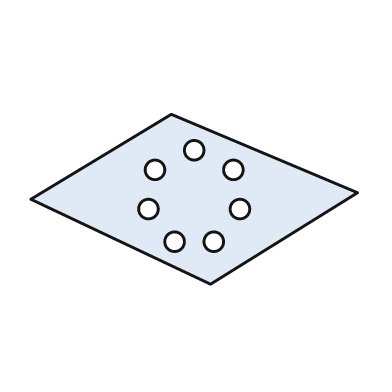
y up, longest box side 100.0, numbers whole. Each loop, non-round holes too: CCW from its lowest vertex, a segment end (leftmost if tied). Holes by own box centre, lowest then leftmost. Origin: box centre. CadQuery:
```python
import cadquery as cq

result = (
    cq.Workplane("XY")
    .moveTo(5.0, -26.0)
    .lineTo(50.0, 2.0)
    .lineTo(-7.0, 26.0)
    .lineTo(-50.0, 0.0)
    .close()
    .moveTo(-6.0, -13.0)
    .circle(3.0)
    .moveTo(6.0, -13.0)
    .circle(3.0)
    .moveTo(-14.0, -3.0)
    .circle(3.0)
    .moveTo(14.0, -3.0)
    .circle(3.0)
    .moveTo(-12.0, 9.0)
    .circle(3.0)
    .moveTo(12.0, 9.0)
    .circle(3.0)
    .moveTo(0.0, 15.0)
    .circle(3.0)
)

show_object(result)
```